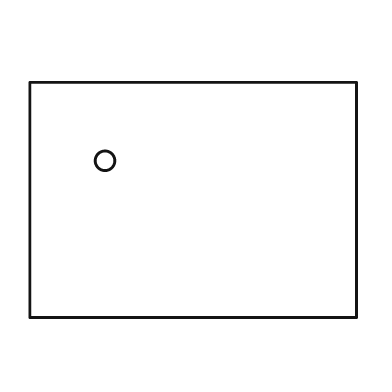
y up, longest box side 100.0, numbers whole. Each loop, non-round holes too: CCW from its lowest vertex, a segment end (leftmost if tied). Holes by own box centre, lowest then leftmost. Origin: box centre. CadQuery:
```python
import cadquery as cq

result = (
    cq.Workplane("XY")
    .moveTo(-50.0, -36.0)
    .lineTo(50.0, -36.0)
    .lineTo(50.0, 36.0)
    .lineTo(-50.0, 36.0)
    .close()
    .moveTo(-27.0, 12.0)
    .circle(3.0)
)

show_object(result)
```